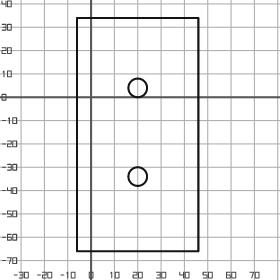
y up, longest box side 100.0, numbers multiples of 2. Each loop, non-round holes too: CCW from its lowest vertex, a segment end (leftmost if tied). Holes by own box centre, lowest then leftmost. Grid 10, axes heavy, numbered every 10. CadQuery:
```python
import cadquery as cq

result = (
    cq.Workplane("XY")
    .moveTo(-6.0, -66.0)
    .lineTo(46.0, -66.0)
    .lineTo(46.0, 34.0)
    .lineTo(-6.0, 34.0)
    .close()
    .moveTo(20.0, -34.0)
    .circle(4.0)
    .moveTo(20.0, 4.0)
    .circle(4.0)
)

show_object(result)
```